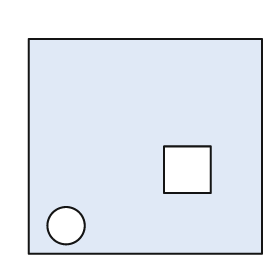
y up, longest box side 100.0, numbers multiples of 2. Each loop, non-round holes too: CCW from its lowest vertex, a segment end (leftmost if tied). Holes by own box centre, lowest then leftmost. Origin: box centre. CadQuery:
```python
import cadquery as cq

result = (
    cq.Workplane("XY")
    .moveTo(-50.0, -46.0)
    .lineTo(50.0, -46.0)
    .lineTo(50.0, 46.0)
    .lineTo(-50.0, 46.0)
    .close()
    .moveTo(-34.0, -34.0)
    .circle(8.0)
    .moveTo(8.0, -20.0)
    .lineTo(28.0, -20.0)
    .lineTo(28.0, 0.0)
    .lineTo(8.0, 0.0)
    .close()
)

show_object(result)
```